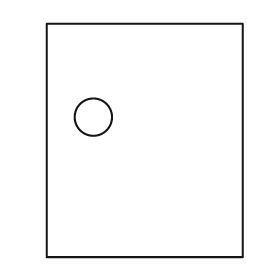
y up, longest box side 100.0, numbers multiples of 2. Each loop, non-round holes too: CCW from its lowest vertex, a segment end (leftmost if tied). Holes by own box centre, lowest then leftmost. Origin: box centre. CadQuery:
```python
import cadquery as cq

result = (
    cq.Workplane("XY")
    .moveTo(-42.0, -50.0)
    .lineTo(42.0, -50.0)
    .lineTo(42.0, 50.0)
    .lineTo(-42.0, 50.0)
    .close()
    .moveTo(-22.0, 10.0)
    .circle(8.0)
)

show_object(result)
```